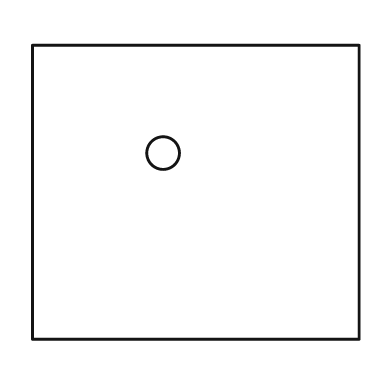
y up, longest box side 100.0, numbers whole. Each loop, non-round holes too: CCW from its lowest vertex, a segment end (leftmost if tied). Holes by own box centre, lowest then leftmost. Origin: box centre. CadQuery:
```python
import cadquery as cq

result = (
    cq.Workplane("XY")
    .moveTo(-50.0, -45.0)
    .lineTo(50.0, -45.0)
    .lineTo(50.0, 45.0)
    .lineTo(-50.0, 45.0)
    .close()
    .moveTo(-10.0, 12.0)
    .circle(5.0)
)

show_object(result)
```